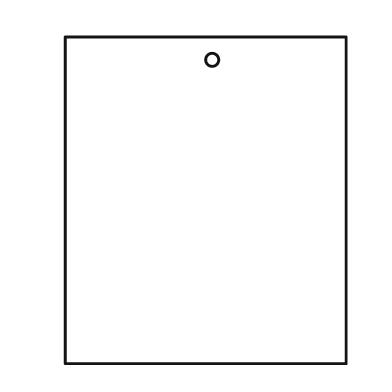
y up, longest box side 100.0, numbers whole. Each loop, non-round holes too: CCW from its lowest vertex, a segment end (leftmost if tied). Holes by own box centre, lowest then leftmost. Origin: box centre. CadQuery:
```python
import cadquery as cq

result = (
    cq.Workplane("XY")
    .moveTo(-43.0, -50.0)
    .lineTo(43.0, -50.0)
    .lineTo(43.0, 50.0)
    .lineTo(-43.0, 50.0)
    .close()
    .moveTo(2.0, 43.0)
    .circle(2.0)
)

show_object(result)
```